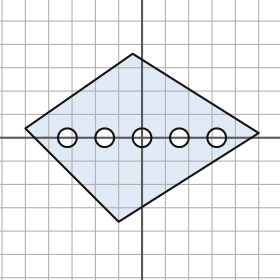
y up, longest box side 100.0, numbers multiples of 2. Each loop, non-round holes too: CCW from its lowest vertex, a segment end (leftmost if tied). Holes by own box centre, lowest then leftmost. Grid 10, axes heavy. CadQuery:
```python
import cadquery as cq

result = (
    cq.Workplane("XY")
    .moveTo(-10.0, -36.0)
    .lineTo(50.0, 2.0)
    .lineTo(-4.0, 36.0)
    .lineTo(-50.0, 4.0)
    .close()
    .moveTo(-32.0, 0.0)
    .circle(4.0)
    .moveTo(-16.0, 0.0)
    .circle(4.0)
    .moveTo(0.0, 0.0)
    .circle(4.0)
    .moveTo(16.0, 0.0)
    .circle(4.0)
    .moveTo(32.0, 0.0)
    .circle(4.0)
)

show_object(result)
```